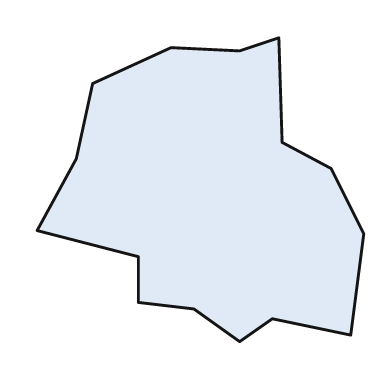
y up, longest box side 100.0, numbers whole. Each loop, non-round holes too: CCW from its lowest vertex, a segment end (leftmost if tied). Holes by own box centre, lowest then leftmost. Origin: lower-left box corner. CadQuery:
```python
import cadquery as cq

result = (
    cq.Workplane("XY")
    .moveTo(62.0, 0.0)
    .lineTo(72.0, 7.0)
    .lineTo(96.0, 2.0)
    .lineTo(100.0, 33.0)
    .lineTo(90.0, 53.0)
    .lineTo(75.0, 61.0)
    .lineTo(74.0, 93.0)
    .lineTo(62.0, 89.0)
    .lineTo(41.0, 90.0)
    .lineTo(17.0, 79.0)
    .lineTo(12.0, 56.0)
    .lineTo(0.0, 34.0)
    .lineTo(31.0, 26.0)
    .lineTo(31.0, 12.0)
    .lineTo(48.0, 10.0)
    .close()
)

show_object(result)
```